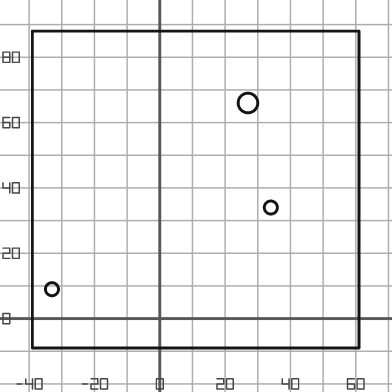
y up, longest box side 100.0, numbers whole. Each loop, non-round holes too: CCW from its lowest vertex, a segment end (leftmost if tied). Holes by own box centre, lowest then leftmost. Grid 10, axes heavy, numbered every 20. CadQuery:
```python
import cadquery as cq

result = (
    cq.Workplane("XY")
    .moveTo(-39.0, -9.0)
    .lineTo(61.0, -9.0)
    .lineTo(61.0, 88.0)
    .lineTo(-39.0, 88.0)
    .close()
    .moveTo(-33.0, 9.0)
    .circle(2.0)
    .moveTo(34.0, 34.0)
    .circle(2.0)
    .moveTo(27.0, 66.0)
    .circle(3.0)
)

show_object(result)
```